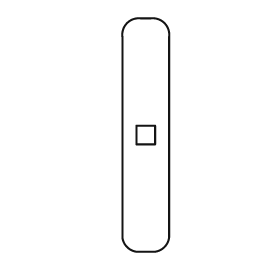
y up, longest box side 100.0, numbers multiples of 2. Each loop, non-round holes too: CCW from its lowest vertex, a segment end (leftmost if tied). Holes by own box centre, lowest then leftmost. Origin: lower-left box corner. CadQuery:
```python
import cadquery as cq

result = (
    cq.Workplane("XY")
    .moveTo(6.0, 0.0)
    .lineTo(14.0, 0.0)
    .threePointArc((18.0, 2.0), (20.0, 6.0))
    .lineTo(20.0, 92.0)
    .threePointArc((18.0, 98.0), (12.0, 100.0))
    .lineTo(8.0, 100.0)
    .threePointArc((2.0, 98.0), (0.0, 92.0))
    .lineTo(0.0, 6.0)
    .threePointArc((2.0, 2.0), (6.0, 0.0))
    .close()
    .moveTo(6.0, 46.0)
    .lineTo(14.0, 46.0)
    .lineTo(14.0, 54.0)
    .lineTo(6.0, 54.0)
    .close()
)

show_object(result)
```